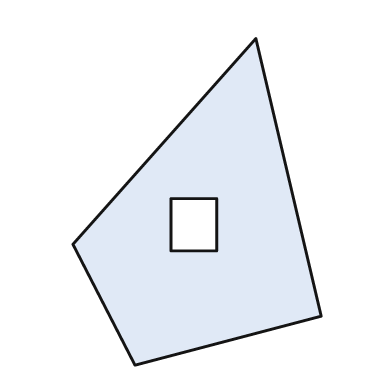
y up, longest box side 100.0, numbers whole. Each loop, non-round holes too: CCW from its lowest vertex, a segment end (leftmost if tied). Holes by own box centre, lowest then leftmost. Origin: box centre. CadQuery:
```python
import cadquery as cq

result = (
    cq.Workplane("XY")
    .moveTo(-19.0, -50.0)
    .lineTo(38.0, -35.0)
    .lineTo(18.0, 50.0)
    .lineTo(-38.0, -13.0)
    .close()
    .moveTo(-8.0, -15.0)
    .lineTo(6.0, -15.0)
    .lineTo(6.0, 1.0)
    .lineTo(-8.0, 1.0)
    .close()
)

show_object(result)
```